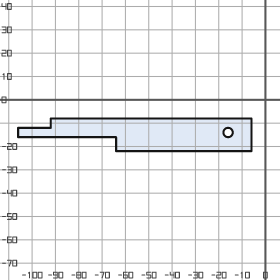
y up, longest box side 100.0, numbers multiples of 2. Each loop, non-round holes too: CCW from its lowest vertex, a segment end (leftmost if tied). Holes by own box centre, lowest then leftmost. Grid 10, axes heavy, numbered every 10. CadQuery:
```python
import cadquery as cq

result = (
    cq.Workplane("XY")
    .moveTo(-64.0, -22.0)
    .lineTo(-6.0, -22.0)
    .lineTo(-6.0, -8.0)
    .lineTo(-92.0, -8.0)
    .lineTo(-92.0, -12.0)
    .lineTo(-106.0, -12.0)
    .lineTo(-106.0, -16.0)
    .lineTo(-64.0, -16.0)
    .close()
    .moveTo(-16.0, -14.0)
    .circle(2.0)
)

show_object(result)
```